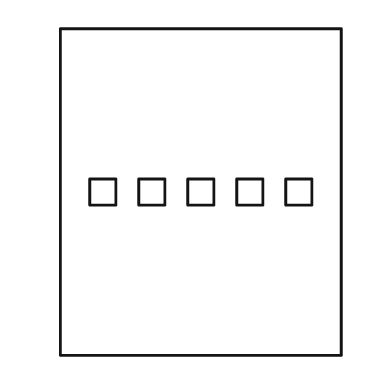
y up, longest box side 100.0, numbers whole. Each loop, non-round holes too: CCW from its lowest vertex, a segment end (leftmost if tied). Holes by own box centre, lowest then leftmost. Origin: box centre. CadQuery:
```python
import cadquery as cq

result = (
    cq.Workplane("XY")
    .moveTo(-43.0, -50.0)
    .lineTo(43.0, -50.0)
    .lineTo(43.0, 50.0)
    .lineTo(-43.0, 50.0)
    .close()
    .moveTo(-34.0, -4.0)
    .lineTo(-26.0, -4.0)
    .lineTo(-26.0, 4.0)
    .lineTo(-34.0, 4.0)
    .close()
    .moveTo(-19.0, -4.0)
    .lineTo(-11.0, -4.0)
    .lineTo(-11.0, 4.0)
    .lineTo(-19.0, 4.0)
    .close()
    .moveTo(-4.0, -4.0)
    .lineTo(4.0, -4.0)
    .lineTo(4.0, 4.0)
    .lineTo(-4.0, 4.0)
    .close()
    .moveTo(11.0, -4.0)
    .lineTo(19.0, -4.0)
    .lineTo(19.0, 4.0)
    .lineTo(11.0, 4.0)
    .close()
    .moveTo(26.0, -4.0)
    .lineTo(34.0, -4.0)
    .lineTo(34.0, 4.0)
    .lineTo(26.0, 4.0)
    .close()
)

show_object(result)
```